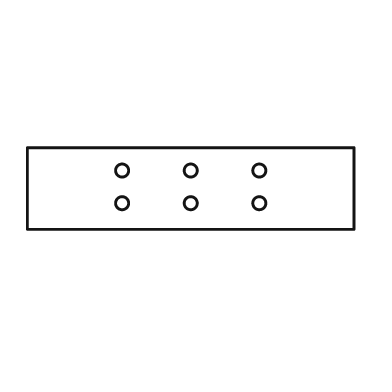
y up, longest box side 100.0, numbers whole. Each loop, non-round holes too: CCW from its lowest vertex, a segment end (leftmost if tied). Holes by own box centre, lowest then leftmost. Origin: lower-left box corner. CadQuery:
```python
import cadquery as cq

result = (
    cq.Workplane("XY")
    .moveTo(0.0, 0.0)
    .lineTo(100.0, 0.0)
    .lineTo(100.0, 25.0)
    .lineTo(0.0, 25.0)
    .close()
    .moveTo(29.0, 8.0)
    .circle(2.0)
    .moveTo(50.0, 8.0)
    .circle(2.0)
    .moveTo(71.0, 8.0)
    .circle(2.0)
    .moveTo(29.0, 18.0)
    .circle(2.0)
    .moveTo(50.0, 18.0)
    .circle(2.0)
    .moveTo(71.0, 18.0)
    .circle(2.0)
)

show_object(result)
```